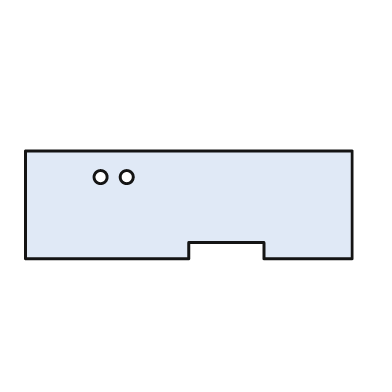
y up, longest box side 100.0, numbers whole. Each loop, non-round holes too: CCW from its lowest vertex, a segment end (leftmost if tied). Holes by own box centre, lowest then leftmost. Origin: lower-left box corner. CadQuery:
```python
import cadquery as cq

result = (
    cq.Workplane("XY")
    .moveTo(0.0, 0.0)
    .lineTo(50.0, 0.0)
    .lineTo(50.0, 5.0)
    .lineTo(73.0, 5.0)
    .lineTo(73.0, 0.0)
    .lineTo(100.0, 0.0)
    .lineTo(100.0, 33.0)
    .lineTo(0.0, 33.0)
    .close()
    .moveTo(23.0, 25.0)
    .circle(2.0)
    .moveTo(31.0, 25.0)
    .circle(2.0)
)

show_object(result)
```